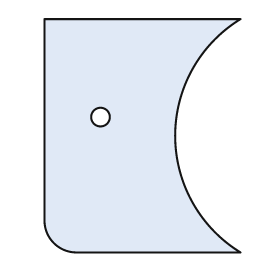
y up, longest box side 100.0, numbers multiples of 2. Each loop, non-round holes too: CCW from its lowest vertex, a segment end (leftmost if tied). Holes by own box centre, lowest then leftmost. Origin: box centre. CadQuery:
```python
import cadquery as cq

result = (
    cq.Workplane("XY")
    .moveTo(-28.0, -50.0)
    .lineTo(42.0, -50.0)
    .threePointArc((14.0, 0.0), (42.0, 50.0))
    .lineTo(-42.0, 50.0)
    .lineTo(-42.0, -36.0)
    .threePointArc((-38.0, -46.0), (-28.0, -50.0))
    .close()
    .moveTo(-18.0, 8.0)
    .circle(4.0)
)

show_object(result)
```